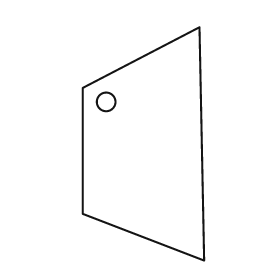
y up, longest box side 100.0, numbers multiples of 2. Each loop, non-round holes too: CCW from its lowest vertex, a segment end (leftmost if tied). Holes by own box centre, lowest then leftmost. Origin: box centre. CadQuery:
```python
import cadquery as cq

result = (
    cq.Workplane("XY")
    .moveTo(26.0, -50.0)
    .lineTo(24.0, 50.0)
    .lineTo(-26.0, 24.0)
    .lineTo(-26.0, -30.0)
    .close()
    .moveTo(-16.0, 18.0)
    .circle(4.0)
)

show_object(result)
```